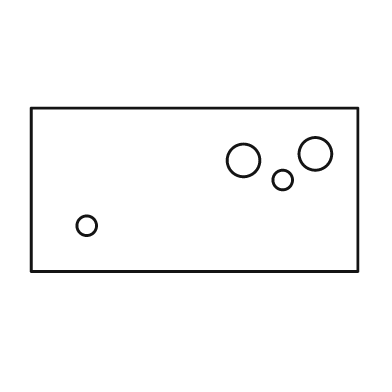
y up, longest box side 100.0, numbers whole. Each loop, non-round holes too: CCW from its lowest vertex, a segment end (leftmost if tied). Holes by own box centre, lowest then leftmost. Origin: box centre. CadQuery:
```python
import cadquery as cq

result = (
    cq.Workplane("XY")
    .moveTo(-50.0, -25.0)
    .lineTo(50.0, -25.0)
    .lineTo(50.0, 25.0)
    .lineTo(-50.0, 25.0)
    .close()
    .moveTo(-33.0, -11.0)
    .circle(3.0)
    .moveTo(27.0, 3.0)
    .circle(3.0)
    .moveTo(15.0, 9.0)
    .circle(5.0)
    .moveTo(37.0, 11.0)
    .circle(5.0)
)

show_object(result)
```